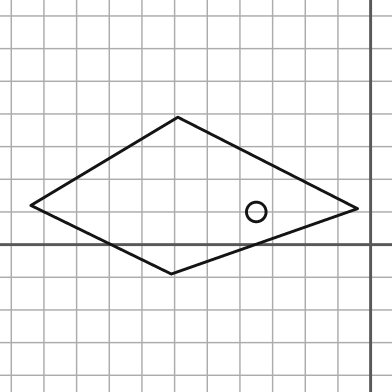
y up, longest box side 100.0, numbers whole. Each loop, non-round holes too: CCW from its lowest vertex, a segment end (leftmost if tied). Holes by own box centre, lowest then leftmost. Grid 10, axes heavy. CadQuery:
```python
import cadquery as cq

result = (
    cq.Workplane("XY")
    .moveTo(-61.0, -9.0)
    .lineTo(-4.0, 11.0)
    .lineTo(-59.0, 39.0)
    .lineTo(-104.0, 12.0)
    .close()
    .moveTo(-35.0, 10.0)
    .circle(3.0)
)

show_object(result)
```